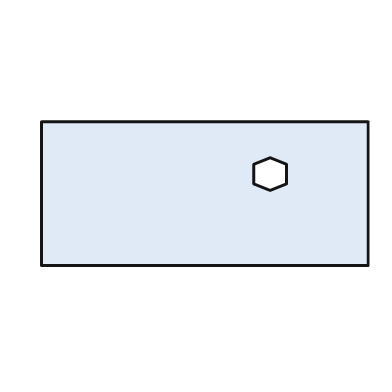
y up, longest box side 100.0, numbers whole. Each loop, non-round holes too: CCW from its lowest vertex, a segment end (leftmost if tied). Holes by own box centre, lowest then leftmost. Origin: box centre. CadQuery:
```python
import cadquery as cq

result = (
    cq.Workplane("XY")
    .moveTo(-50.0, -22.0)
    .lineTo(50.0, -22.0)
    .lineTo(50.0, 22.0)
    .lineTo(-50.0, 22.0)
    .close()
    .moveTo(20.0, 1.0)
    .lineTo(25.0, 3.0)
    .lineTo(25.0, 9.0)
    .lineTo(20.0, 11.0)
    .lineTo(15.0, 9.0)
    .lineTo(15.0, 3.0)
    .close()
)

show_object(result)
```